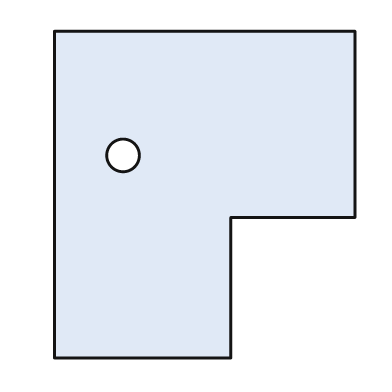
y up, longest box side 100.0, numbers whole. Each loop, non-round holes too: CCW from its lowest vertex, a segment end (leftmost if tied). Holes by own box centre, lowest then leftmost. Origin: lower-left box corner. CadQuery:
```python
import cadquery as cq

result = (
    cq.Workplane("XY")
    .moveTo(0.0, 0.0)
    .lineTo(54.0, 0.0)
    .lineTo(54.0, 43.0)
    .lineTo(92.0, 43.0)
    .lineTo(92.0, 100.0)
    .lineTo(0.0, 100.0)
    .close()
    .moveTo(21.0, 62.0)
    .circle(5.0)
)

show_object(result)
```